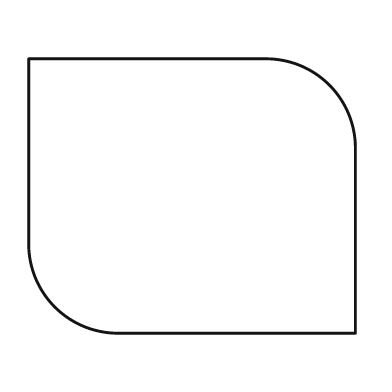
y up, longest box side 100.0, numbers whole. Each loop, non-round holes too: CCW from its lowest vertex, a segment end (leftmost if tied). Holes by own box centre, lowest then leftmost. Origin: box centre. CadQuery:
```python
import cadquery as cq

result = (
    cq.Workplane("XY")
    .moveTo(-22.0, -42.0)
    .lineTo(50.0, -42.0)
    .lineTo(50.0, 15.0)
    .threePointArc((42.0, 34.0), (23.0, 42.0))
    .lineTo(-50.0, 42.0)
    .lineTo(-50.0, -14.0)
    .threePointArc((-42.0, -34.0), (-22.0, -42.0))
    .close()
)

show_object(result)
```